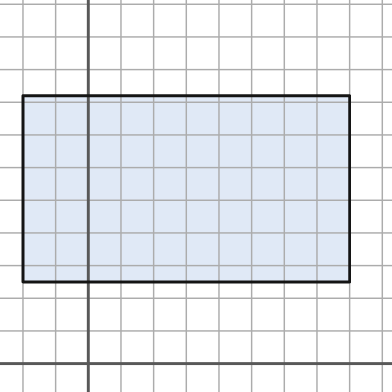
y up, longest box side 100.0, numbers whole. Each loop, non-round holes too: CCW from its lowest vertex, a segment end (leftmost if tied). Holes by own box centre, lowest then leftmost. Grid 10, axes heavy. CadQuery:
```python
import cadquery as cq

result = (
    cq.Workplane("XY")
    .moveTo(-20.0, 25.0)
    .lineTo(80.0, 25.0)
    .lineTo(80.0, 82.0)
    .lineTo(-20.0, 82.0)
    .close()
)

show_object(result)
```